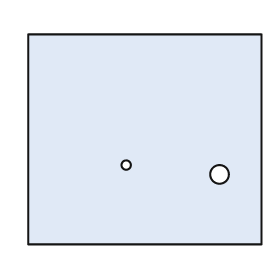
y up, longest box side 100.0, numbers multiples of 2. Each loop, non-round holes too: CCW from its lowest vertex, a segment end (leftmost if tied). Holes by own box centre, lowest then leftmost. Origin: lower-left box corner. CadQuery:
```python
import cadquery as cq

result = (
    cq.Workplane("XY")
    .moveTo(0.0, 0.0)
    .lineTo(100.0, 0.0)
    .lineTo(100.0, 90.0)
    .lineTo(0.0, 90.0)
    .close()
    .moveTo(82.0, 30.0)
    .circle(4.0)
    .moveTo(42.0, 34.0)
    .circle(2.0)
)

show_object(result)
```